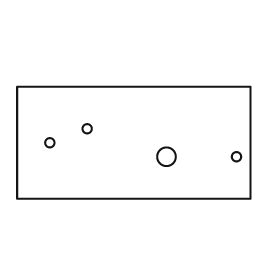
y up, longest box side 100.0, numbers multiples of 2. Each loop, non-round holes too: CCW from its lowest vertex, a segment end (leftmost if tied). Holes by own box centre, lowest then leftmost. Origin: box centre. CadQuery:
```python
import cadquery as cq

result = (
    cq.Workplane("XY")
    .moveTo(-50.0, -24.0)
    .lineTo(50.0, -24.0)
    .lineTo(50.0, 24.0)
    .lineTo(-50.0, 24.0)
    .close()
    .moveTo(14.0, -6.0)
    .circle(4.0)
    .moveTo(44.0, -6.0)
    .circle(2.0)
    .moveTo(-36.0, 0.0)
    .circle(2.0)
    .moveTo(-20.0, 6.0)
    .circle(2.0)
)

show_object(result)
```